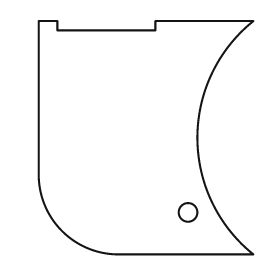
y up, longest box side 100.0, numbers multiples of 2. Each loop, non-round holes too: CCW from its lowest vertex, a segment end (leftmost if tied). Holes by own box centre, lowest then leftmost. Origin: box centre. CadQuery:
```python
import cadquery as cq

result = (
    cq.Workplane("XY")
    .moveTo(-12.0, -50.0)
    .lineTo(46.0, -50.0)
    .threePointArc((22.0, 0.0), (46.0, 50.0))
    .lineTo(4.0, 50.0)
    .lineTo(4.0, 46.0)
    .lineTo(-38.0, 46.0)
    .lineTo(-38.0, 50.0)
    .lineTo(-46.0, 50.0)
    .lineTo(-46.0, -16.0)
    .threePointArc((-36.0, -40.0), (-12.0, -50.0))
    .close()
    .moveTo(18.0, -32.0)
    .circle(4.0)
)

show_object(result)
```